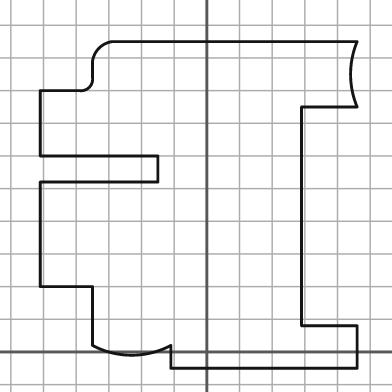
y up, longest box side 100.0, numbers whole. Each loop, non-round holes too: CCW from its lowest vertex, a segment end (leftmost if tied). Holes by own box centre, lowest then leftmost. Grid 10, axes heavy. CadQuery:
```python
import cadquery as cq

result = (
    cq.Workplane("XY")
    .moveTo(-11.0, -5.0)
    .lineTo(46.0, -5.0)
    .lineTo(46.0, 8.0)
    .lineTo(29.0, 8.0)
    .lineTo(29.0, 75.0)
    .lineTo(46.0, 75.0)
    .threePointArc((44.0, 85.0), (46.0, 95.0))
    .lineTo(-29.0, 95.0)
    .threePointArc((-33.0, 93.0), (-35.0, 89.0))
    .lineTo(-35.0, 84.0)
    .threePointArc((-36.0, 81.0), (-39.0, 80.0))
    .lineTo(-51.0, 80.0)
    .lineTo(-51.0, 60.0)
    .lineTo(-15.0, 60.0)
    .lineTo(-15.0, 52.0)
    .lineTo(-51.0, 52.0)
    .lineTo(-51.0, 20.0)
    .lineTo(-35.0, 20.0)
    .lineTo(-35.0, 2.0)
    .threePointArc((-23.0, -1.0), (-11.0, 2.0))
    .close()
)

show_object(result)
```